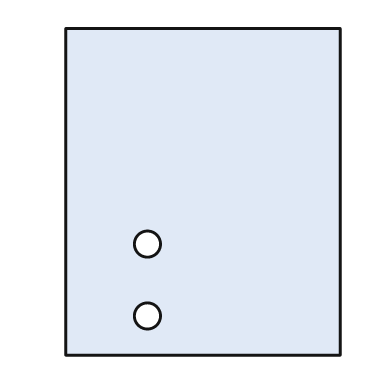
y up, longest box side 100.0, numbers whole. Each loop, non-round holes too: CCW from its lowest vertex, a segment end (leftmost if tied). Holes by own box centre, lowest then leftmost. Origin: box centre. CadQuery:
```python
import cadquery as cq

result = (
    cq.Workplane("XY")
    .moveTo(-42.0, -50.0)
    .lineTo(42.0, -50.0)
    .lineTo(42.0, 50.0)
    .lineTo(-42.0, 50.0)
    .close()
    .moveTo(-17.0, -38.0)
    .circle(4.0)
    .moveTo(-17.0, -16.0)
    .circle(4.0)
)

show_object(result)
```